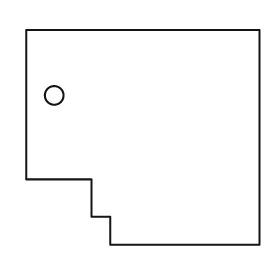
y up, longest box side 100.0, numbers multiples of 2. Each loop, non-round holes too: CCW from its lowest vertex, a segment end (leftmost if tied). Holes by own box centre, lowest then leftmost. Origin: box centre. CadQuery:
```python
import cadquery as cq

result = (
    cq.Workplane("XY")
    .moveTo(-14.0, -46.0)
    .lineTo(50.0, -46.0)
    .lineTo(50.0, 46.0)
    .lineTo(-50.0, 46.0)
    .lineTo(-50.0, -18.0)
    .lineTo(-22.0, -18.0)
    .lineTo(-22.0, -34.0)
    .lineTo(-14.0, -34.0)
    .close()
    .moveTo(-38.0, 18.0)
    .circle(4.0)
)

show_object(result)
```